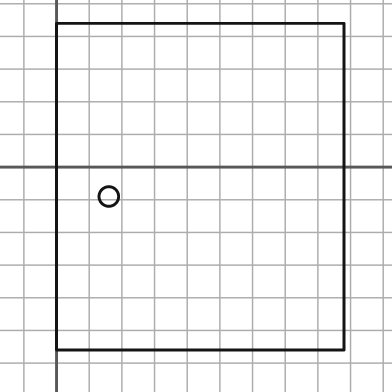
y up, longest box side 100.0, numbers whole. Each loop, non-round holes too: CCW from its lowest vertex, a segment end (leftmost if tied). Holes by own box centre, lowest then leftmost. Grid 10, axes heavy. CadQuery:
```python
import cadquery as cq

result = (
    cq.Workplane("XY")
    .moveTo(0.0, -56.0)
    .lineTo(88.0, -56.0)
    .lineTo(88.0, 44.0)
    .lineTo(0.0, 44.0)
    .close()
    .moveTo(16.0, -9.0)
    .circle(3.0)
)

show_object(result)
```